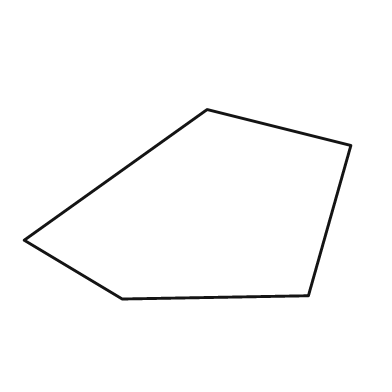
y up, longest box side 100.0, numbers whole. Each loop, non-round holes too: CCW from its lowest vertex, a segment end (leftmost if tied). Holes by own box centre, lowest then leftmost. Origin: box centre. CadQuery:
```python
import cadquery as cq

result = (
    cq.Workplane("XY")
    .moveTo(-20.0, -29.0)
    .lineTo(37.0, -28.0)
    .lineTo(50.0, 18.0)
    .lineTo(6.0, 29.0)
    .lineTo(-50.0, -11.0)
    .close()
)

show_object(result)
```